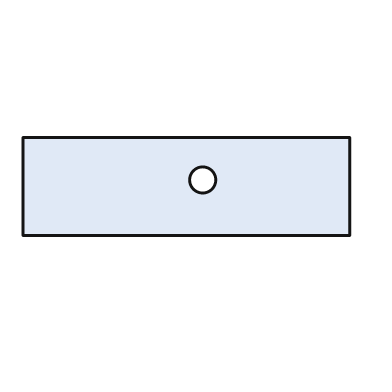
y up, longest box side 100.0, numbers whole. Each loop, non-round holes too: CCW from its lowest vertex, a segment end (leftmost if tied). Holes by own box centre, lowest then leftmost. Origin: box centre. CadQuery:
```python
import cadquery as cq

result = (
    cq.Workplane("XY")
    .moveTo(-50.0, -15.0)
    .lineTo(50.0, -15.0)
    .lineTo(50.0, 15.0)
    .lineTo(-50.0, 15.0)
    .close()
    .moveTo(5.0, 2.0)
    .circle(4.0)
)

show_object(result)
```